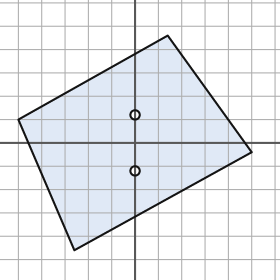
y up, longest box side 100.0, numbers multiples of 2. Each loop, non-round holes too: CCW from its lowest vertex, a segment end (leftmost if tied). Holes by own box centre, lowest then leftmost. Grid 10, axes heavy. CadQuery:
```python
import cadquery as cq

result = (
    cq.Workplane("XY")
    .moveTo(-26.0, -46.0)
    .lineTo(50.0, -4.0)
    .lineTo(14.0, 46.0)
    .lineTo(-50.0, 10.0)
    .close()
    .moveTo(0.0, -12.0)
    .circle(2.0)
    .moveTo(0.0, 12.0)
    .circle(2.0)
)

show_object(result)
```